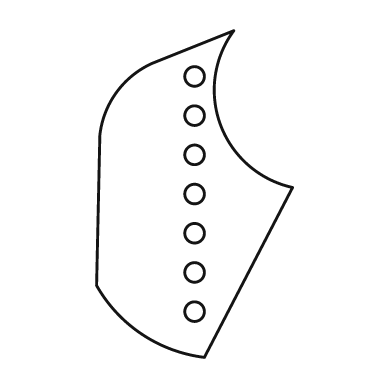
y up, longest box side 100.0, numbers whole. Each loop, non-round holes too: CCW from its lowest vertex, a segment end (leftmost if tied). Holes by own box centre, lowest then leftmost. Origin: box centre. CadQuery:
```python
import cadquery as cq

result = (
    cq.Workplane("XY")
    .moveTo(3.0, -50.0)
    .lineTo(30.0, 2.0)
    .threePointArc((8.0, 21.0), (12.0, 50.0))
    .lineTo(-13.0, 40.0)
    .threePointArc((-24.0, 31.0), (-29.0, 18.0))
    .lineTo(-30.0, -28.0)
    .threePointArc((-16.0, -43.0), (3.0, -50.0))
    .close()
    .moveTo(0.0, -36.0)
    .circle(3.0)
    .moveTo(0.0, -24.0)
    .circle(3.0)
    .moveTo(0.0, -12.0)
    .circle(3.0)
    .moveTo(0.0, 0.0)
    .circle(3.0)
    .moveTo(0.0, 12.0)
    .circle(3.0)
    .moveTo(0.0, 24.0)
    .circle(3.0)
    .moveTo(0.0, 36.0)
    .circle(3.0)
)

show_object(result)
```